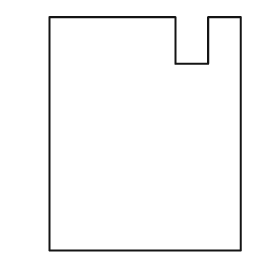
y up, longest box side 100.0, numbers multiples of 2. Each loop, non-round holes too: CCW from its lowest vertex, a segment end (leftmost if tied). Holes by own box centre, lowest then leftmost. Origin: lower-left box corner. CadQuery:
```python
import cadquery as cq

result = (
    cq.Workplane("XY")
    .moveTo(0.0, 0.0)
    .lineTo(82.0, 0.0)
    .lineTo(82.0, 100.0)
    .lineTo(68.0, 100.0)
    .lineTo(68.0, 80.0)
    .lineTo(54.0, 80.0)
    .lineTo(54.0, 100.0)
    .lineTo(0.0, 100.0)
    .close()
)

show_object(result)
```